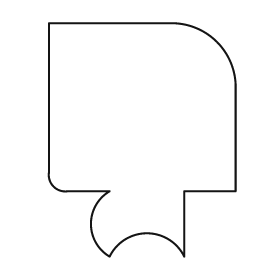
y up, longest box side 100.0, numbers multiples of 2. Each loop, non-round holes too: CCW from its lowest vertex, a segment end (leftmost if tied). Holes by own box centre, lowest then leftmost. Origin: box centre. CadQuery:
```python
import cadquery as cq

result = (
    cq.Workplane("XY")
    .moveTo(-14.0, -50.0)
    .threePointArc((2.0, -40.0), (18.0, -50.0))
    .lineTo(18.0, -22.0)
    .lineTo(40.0, -22.0)
    .lineTo(40.0, 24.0)
    .threePointArc((32.0, 42.0), (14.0, 50.0))
    .lineTo(-40.0, 50.0)
    .lineTo(-40.0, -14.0)
    .threePointArc((-38.0, -20.0), (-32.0, -22.0))
    .lineTo(-14.0, -22.0)
    .threePointArc((-22.0, -36.0), (-14.0, -50.0))
    .close()
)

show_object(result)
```